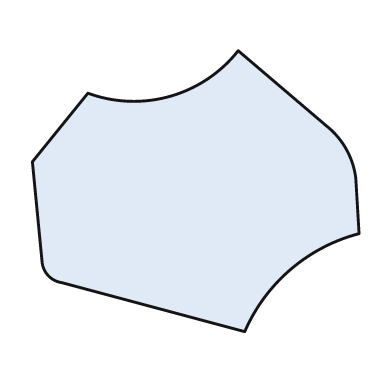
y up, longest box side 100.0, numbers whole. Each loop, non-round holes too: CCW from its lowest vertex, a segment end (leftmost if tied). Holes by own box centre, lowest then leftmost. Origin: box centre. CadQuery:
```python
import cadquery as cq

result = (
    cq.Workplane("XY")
    .moveTo(15.0, -43.0)
    .threePointArc((29.0, -24.0), (50.0, -13.0))
    .lineTo(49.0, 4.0)
    .threePointArc((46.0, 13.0), (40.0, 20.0))
    .lineTo(13.0, 43.0)
    .threePointArc((-8.0, 29.0), (-33.0, 30.0))
    .lineTo(-50.0, 9.0)
    .lineTo(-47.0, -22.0)
    .threePointArc((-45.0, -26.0), (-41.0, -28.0))
    .close()
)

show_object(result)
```